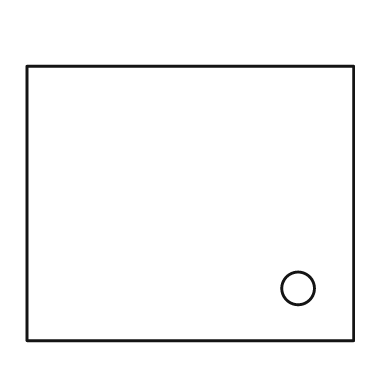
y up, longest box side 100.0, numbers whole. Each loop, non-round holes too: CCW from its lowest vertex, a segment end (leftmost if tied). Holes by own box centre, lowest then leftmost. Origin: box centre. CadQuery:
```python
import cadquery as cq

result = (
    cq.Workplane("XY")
    .moveTo(-50.0, -42.0)
    .lineTo(50.0, -42.0)
    .lineTo(50.0, 42.0)
    .lineTo(-50.0, 42.0)
    .close()
    .moveTo(33.0, -26.0)
    .circle(5.0)
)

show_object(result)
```